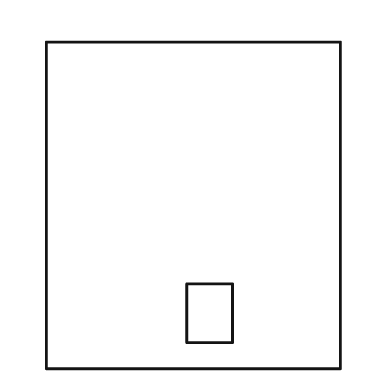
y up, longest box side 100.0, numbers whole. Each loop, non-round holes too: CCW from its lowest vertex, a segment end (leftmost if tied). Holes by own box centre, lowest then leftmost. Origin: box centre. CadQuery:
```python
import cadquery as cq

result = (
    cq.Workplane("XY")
    .moveTo(-45.0, -50.0)
    .lineTo(45.0, -50.0)
    .lineTo(45.0, 50.0)
    .lineTo(-45.0, 50.0)
    .close()
    .moveTo(-2.0, -42.0)
    .lineTo(12.0, -42.0)
    .lineTo(12.0, -24.0)
    .lineTo(-2.0, -24.0)
    .close()
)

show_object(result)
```